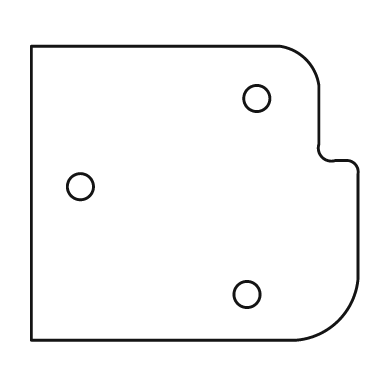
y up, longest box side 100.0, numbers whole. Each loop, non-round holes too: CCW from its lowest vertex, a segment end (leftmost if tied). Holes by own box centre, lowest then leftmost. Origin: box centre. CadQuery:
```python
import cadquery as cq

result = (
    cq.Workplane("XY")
    .moveTo(-50.0, -45.0)
    .lineTo(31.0, -45.0)
    .threePointArc((44.0, -39.0), (50.0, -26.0))
    .lineTo(50.0, 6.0)
    .threePointArc((49.0, 9.0), (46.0, 10.0))
    .lineTo(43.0, 10.0)
    .threePointArc((39.0, 11.0), (38.0, 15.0))
    .lineTo(38.0, 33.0)
    .threePointArc((34.0, 41.0), (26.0, 45.0))
    .lineTo(-50.0, 45.0)
    .close()
    .moveTo(16.0, -31.0)
    .circle(4.0)
    .moveTo(-35.0, 2.0)
    .circle(4.0)
    .moveTo(19.0, 29.0)
    .circle(4.0)
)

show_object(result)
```